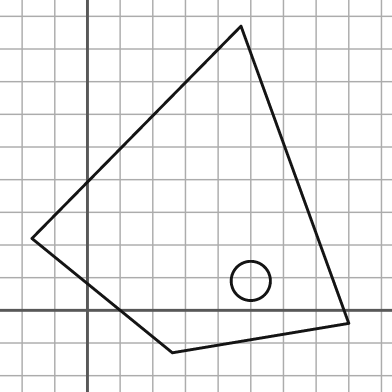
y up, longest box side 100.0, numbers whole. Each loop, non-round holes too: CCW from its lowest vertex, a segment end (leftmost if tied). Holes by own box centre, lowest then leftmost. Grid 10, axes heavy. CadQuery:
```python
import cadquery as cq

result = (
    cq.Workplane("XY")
    .moveTo(26.0, -13.0)
    .lineTo(80.0, -4.0)
    .lineTo(47.0, 87.0)
    .lineTo(-17.0, 22.0)
    .close()
    .moveTo(50.0, 9.0)
    .circle(6.0)
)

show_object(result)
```